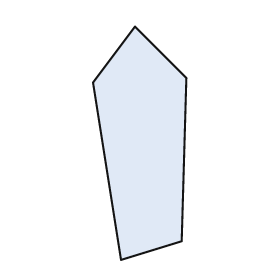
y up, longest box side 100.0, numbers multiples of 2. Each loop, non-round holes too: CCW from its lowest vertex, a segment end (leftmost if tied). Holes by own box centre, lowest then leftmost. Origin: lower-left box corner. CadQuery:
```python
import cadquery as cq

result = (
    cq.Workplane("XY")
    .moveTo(12.0, 0.0)
    .lineTo(38.0, 8.0)
    .lineTo(40.0, 78.0)
    .lineTo(18.0, 100.0)
    .lineTo(0.0, 76.0)
    .close()
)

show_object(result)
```